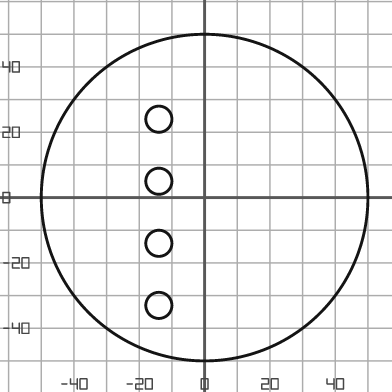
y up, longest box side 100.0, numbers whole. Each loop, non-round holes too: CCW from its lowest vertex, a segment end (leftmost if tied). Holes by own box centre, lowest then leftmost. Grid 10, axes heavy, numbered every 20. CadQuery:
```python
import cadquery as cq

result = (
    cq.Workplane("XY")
    .moveTo(0.0, 0.0)
    .circle(50.0)
    .moveTo(-14.0, -33.0)
    .circle(4.0)
    .moveTo(-14.0, -14.0)
    .circle(4.0)
    .moveTo(-14.0, 5.0)
    .circle(4.0)
    .moveTo(-14.0, 24.0)
    .circle(4.0)
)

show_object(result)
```